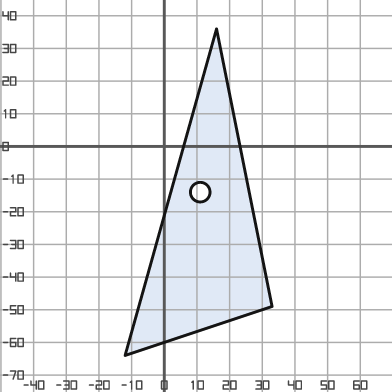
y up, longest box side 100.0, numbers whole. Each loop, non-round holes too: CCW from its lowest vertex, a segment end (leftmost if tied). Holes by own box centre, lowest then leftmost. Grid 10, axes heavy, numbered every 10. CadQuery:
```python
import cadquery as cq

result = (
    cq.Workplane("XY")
    .moveTo(-12.0, -64.0)
    .lineTo(33.0, -49.0)
    .lineTo(16.0, 36.0)
    .close()
    .moveTo(11.0, -14.0)
    .circle(3.0)
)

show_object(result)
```